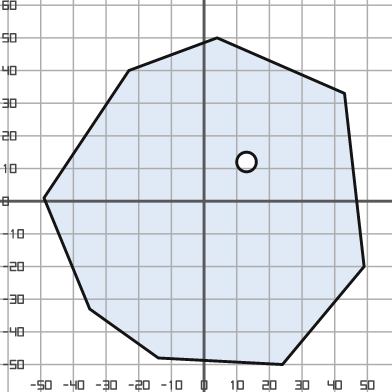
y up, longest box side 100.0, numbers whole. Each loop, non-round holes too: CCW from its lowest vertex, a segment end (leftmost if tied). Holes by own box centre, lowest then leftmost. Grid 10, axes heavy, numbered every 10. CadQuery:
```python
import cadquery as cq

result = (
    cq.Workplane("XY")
    .moveTo(24.0, -50.0)
    .lineTo(49.0, -20.0)
    .lineTo(43.0, 33.0)
    .lineTo(4.0, 50.0)
    .lineTo(-23.0, 40.0)
    .lineTo(-49.0, 1.0)
    .lineTo(-35.0, -33.0)
    .lineTo(-14.0, -48.0)
    .close()
    .moveTo(13.0, 12.0)
    .circle(3.0)
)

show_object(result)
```